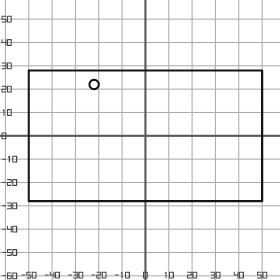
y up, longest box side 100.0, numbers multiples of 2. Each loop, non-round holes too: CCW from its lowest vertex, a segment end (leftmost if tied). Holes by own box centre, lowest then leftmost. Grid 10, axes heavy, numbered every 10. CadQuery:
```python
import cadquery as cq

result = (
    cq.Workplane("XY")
    .moveTo(-50.0, -28.0)
    .lineTo(50.0, -28.0)
    .lineTo(50.0, 28.0)
    .lineTo(-50.0, 28.0)
    .close()
    .moveTo(-22.0, 22.0)
    .circle(2.0)
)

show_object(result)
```